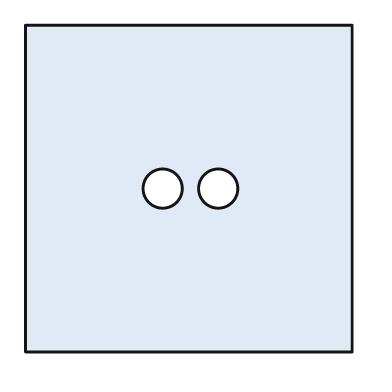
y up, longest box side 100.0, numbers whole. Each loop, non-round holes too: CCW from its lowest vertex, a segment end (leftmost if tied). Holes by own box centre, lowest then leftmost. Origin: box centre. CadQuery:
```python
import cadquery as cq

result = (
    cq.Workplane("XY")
    .moveTo(-50.0, -50.0)
    .lineTo(50.0, -50.0)
    .lineTo(50.0, 50.0)
    .lineTo(-50.0, 50.0)
    .close()
    .moveTo(-8.0, 0.0)
    .circle(6.0)
    .moveTo(9.0, 0.0)
    .circle(6.0)
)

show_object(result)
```